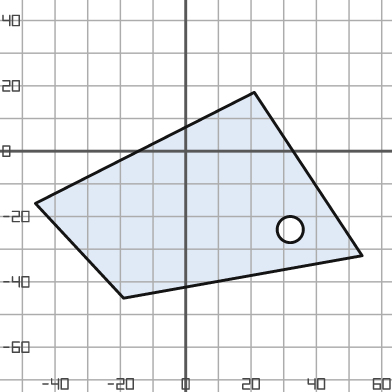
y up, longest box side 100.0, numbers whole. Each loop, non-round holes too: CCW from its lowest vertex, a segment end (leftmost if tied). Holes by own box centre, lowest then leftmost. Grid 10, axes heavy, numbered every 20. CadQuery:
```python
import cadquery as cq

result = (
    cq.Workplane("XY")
    .moveTo(-19.0, -45.0)
    .lineTo(54.0, -32.0)
    .lineTo(21.0, 18.0)
    .lineTo(-46.0, -16.0)
    .close()
    .moveTo(32.0, -24.0)
    .circle(4.0)
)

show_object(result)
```